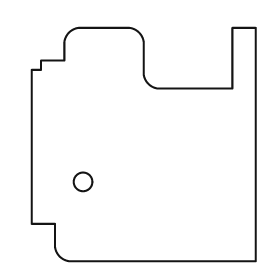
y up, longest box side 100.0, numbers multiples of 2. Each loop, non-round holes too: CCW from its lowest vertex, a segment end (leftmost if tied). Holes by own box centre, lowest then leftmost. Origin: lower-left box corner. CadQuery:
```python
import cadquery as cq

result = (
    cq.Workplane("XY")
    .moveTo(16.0, 0.0)
    .lineTo(96.0, 0.0)
    .lineTo(96.0, 100.0)
    .lineTo(86.0, 100.0)
    .lineTo(86.0, 74.0)
    .lineTo(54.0, 74.0)
    .threePointArc((50.0, 76.0), (48.0, 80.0))
    .lineTo(48.0, 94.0)
    .threePointArc((46.0, 98.0), (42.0, 100.0))
    .lineTo(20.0, 100.0)
    .threePointArc((16.0, 98.0), (14.0, 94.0))
    .lineTo(14.0, 86.0)
    .lineTo(4.0, 86.0)
    .lineTo(4.0, 82.0)
    .lineTo(0.0, 82.0)
    .lineTo(0.0, 16.0)
    .lineTo(10.0, 16.0)
    .lineTo(10.0, 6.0)
    .threePointArc((12.0, 2.0), (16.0, 0.0))
    .close()
    .moveTo(22.0, 34.0)
    .circle(4.0)
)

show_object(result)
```